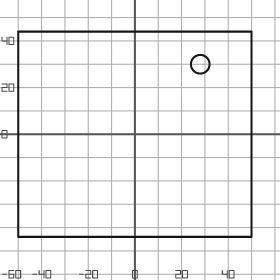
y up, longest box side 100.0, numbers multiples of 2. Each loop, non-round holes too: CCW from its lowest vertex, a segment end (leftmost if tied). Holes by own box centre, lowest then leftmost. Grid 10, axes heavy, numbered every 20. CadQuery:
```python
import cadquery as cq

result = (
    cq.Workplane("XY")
    .moveTo(-50.0, -44.0)
    .lineTo(50.0, -44.0)
    .lineTo(50.0, 44.0)
    .lineTo(-50.0, 44.0)
    .close()
    .moveTo(28.0, 30.0)
    .circle(4.0)
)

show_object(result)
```